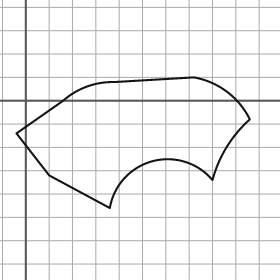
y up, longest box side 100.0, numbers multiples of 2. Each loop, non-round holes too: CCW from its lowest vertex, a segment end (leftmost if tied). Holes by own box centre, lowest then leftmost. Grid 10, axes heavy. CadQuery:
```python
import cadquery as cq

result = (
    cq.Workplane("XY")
    .moveTo(36.0, -46.0)
    .threePointArc((54.0, -26.0), (80.0, -34.0))
    .threePointArc((86.0, -20.0), (96.0, -8.0))
    .threePointArc((86.0, 4.0), (72.0, 10.0))
    .lineTo(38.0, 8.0)
    .threePointArc((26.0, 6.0), (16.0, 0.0))
    .lineTo(-4.0, -14.0)
    .lineTo(10.0, -32.0)
    .close()
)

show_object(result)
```